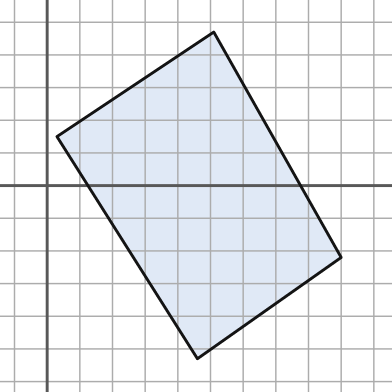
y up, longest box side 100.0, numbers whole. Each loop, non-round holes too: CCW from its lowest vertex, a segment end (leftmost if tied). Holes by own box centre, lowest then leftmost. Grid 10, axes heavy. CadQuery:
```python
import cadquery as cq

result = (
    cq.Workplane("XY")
    .moveTo(46.0, -53.0)
    .lineTo(90.0, -22.0)
    .lineTo(51.0, 47.0)
    .lineTo(3.0, 15.0)
    .close()
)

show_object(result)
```